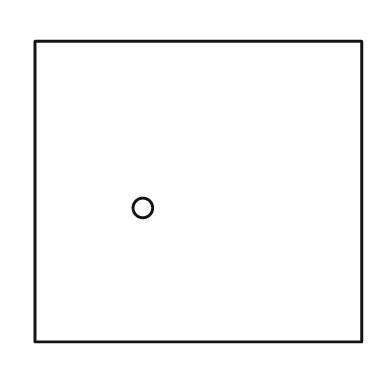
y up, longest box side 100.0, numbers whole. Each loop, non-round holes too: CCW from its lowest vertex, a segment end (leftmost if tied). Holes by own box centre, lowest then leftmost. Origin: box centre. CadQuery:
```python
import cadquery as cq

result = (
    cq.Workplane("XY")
    .moveTo(-50.0, -46.0)
    .lineTo(50.0, -46.0)
    .lineTo(50.0, 46.0)
    .lineTo(-50.0, 46.0)
    .close()
    .moveTo(-17.0, -5.0)
    .circle(3.0)
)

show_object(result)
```